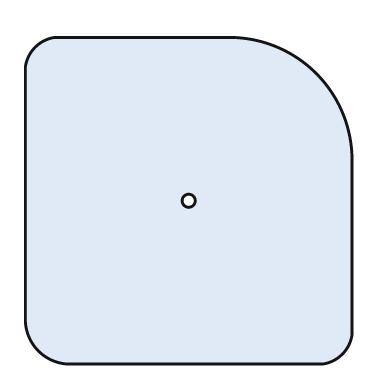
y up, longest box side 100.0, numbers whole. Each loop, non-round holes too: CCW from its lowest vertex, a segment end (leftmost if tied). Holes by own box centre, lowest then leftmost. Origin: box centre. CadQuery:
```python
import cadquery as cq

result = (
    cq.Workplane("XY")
    .moveTo(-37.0, -50.0)
    .lineTo(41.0, -50.0)
    .threePointArc((47.0, -47.0), (50.0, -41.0))
    .lineTo(50.0, 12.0)
    .threePointArc((39.0, 39.0), (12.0, 50.0))
    .lineTo(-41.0, 50.0)
    .threePointArc((-47.0, 47.0), (-50.0, 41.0))
    .lineTo(-50.0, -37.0)
    .threePointArc((-46.0, -46.0), (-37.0, -50.0))
    .close()
    .moveTo(0.0, 0.0)
    .circle(2.0)
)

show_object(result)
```